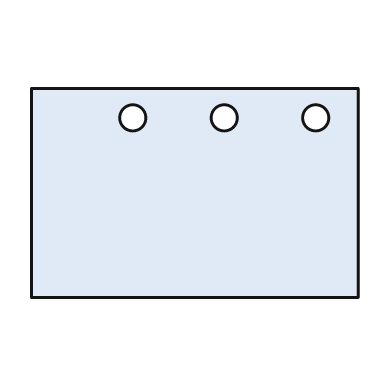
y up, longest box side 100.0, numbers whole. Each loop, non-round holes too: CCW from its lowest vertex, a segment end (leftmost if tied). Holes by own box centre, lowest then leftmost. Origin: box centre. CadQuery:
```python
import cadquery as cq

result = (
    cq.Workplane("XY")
    .moveTo(-50.0, -32.0)
    .lineTo(50.0, -32.0)
    .lineTo(50.0, 32.0)
    .lineTo(-50.0, 32.0)
    .close()
    .moveTo(-19.0, 23.0)
    .circle(4.0)
    .moveTo(9.0, 23.0)
    .circle(4.0)
    .moveTo(37.0, 23.0)
    .circle(4.0)
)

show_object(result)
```